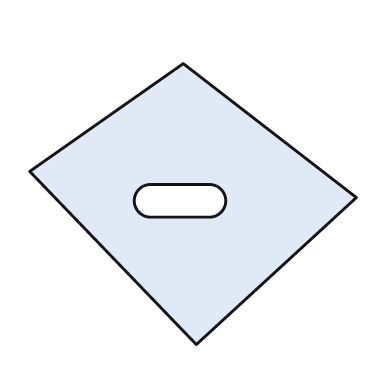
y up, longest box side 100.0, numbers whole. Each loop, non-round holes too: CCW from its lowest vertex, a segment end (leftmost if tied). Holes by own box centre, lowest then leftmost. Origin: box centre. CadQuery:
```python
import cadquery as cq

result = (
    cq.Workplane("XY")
    .moveTo(1.0, -43.0)
    .lineTo(50.0, 2.0)
    .lineTo(-3.0, 43.0)
    .lineTo(-50.0, 10.0)
    .close()
    .moveTo(-13.0, -4.0)
    .lineTo(5.0, -4.0)
    .threePointArc((10.0, 1.0), (5.0, 6.0))
    .lineTo(-13.0, 6.0)
    .threePointArc((-18.0, 1.0), (-13.0, -4.0))
    .close()
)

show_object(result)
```